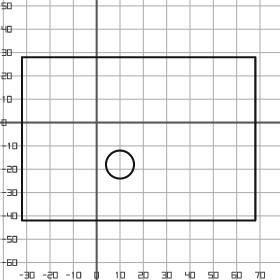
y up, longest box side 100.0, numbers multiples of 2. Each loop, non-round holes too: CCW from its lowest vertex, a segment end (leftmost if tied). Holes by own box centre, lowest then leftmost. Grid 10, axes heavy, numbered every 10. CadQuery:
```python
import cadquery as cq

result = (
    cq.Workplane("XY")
    .moveTo(-32.0, -42.0)
    .lineTo(68.0, -42.0)
    .lineTo(68.0, 28.0)
    .lineTo(-32.0, 28.0)
    .close()
    .moveTo(10.0, -18.0)
    .circle(6.0)
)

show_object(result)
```